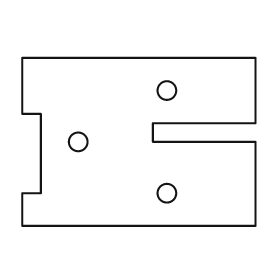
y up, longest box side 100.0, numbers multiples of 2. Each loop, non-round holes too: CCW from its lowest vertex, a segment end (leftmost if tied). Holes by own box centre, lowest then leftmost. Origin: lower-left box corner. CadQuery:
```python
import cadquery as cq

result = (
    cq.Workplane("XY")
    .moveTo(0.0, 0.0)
    .lineTo(100.0, 0.0)
    .lineTo(100.0, 36.0)
    .lineTo(56.0, 36.0)
    .lineTo(56.0, 44.0)
    .lineTo(100.0, 44.0)
    .lineTo(100.0, 72.0)
    .lineTo(0.0, 72.0)
    .lineTo(0.0, 48.0)
    .lineTo(8.0, 48.0)
    .lineTo(8.0, 14.0)
    .lineTo(0.0, 14.0)
    .close()
    .moveTo(62.0, 14.0)
    .circle(4.0)
    .moveTo(24.0, 36.0)
    .circle(4.0)
    .moveTo(62.0, 58.0)
    .circle(4.0)
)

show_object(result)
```